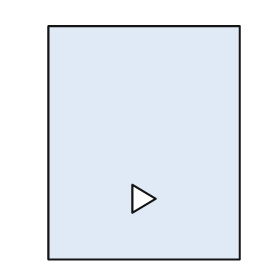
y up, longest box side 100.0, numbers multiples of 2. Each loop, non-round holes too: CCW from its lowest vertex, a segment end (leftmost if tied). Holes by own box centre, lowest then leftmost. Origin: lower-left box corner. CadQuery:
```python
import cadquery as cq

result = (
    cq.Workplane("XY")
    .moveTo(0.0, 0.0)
    .lineTo(82.0, 0.0)
    .lineTo(82.0, 100.0)
    .lineTo(0.0, 100.0)
    .close()
    .moveTo(36.0, 20.0)
    .lineTo(46.0, 26.0)
    .lineTo(36.0, 32.0)
    .close()
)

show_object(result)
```